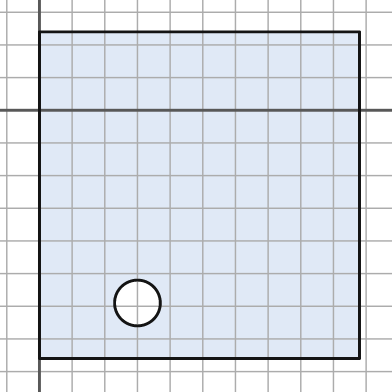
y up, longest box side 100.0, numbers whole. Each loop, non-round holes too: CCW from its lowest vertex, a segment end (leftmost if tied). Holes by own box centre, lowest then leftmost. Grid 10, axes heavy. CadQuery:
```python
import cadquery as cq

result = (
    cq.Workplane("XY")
    .moveTo(0.0, -76.0)
    .lineTo(98.0, -76.0)
    .lineTo(98.0, 24.0)
    .lineTo(0.0, 24.0)
    .close()
    .moveTo(30.0, -59.0)
    .circle(7.0)
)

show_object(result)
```